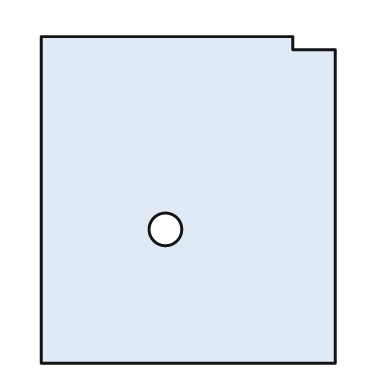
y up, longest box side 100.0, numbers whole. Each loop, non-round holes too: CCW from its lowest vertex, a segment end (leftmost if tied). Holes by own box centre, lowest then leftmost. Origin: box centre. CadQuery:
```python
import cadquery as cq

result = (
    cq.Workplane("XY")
    .moveTo(-45.0, -50.0)
    .lineTo(45.0, -50.0)
    .lineTo(45.0, 46.0)
    .lineTo(32.0, 46.0)
    .lineTo(32.0, 50.0)
    .lineTo(-45.0, 50.0)
    .close()
    .moveTo(-7.0, -9.0)
    .circle(5.0)
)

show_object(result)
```